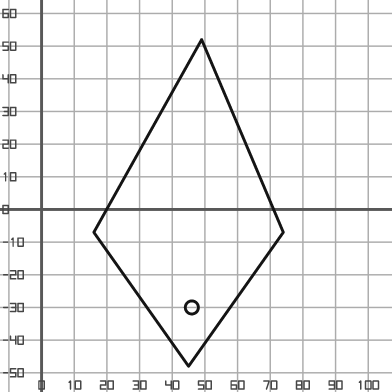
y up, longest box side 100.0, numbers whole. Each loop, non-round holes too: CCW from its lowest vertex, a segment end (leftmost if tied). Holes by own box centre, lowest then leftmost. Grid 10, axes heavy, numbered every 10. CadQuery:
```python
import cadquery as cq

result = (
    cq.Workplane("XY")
    .moveTo(45.0, -48.0)
    .lineTo(74.0, -7.0)
    .lineTo(49.0, 52.0)
    .lineTo(16.0, -7.0)
    .close()
    .moveTo(46.0, -30.0)
    .circle(2.0)
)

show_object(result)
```